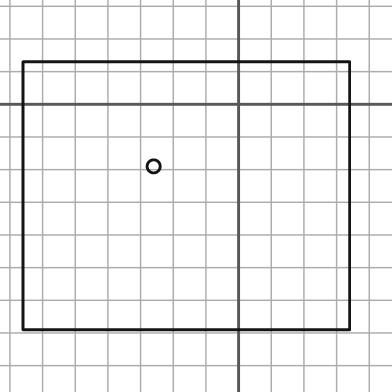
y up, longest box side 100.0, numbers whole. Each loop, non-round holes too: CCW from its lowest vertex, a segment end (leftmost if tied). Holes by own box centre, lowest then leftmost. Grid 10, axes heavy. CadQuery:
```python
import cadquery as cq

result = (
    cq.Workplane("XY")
    .moveTo(-66.0, -69.0)
    .lineTo(34.0, -69.0)
    .lineTo(34.0, 13.0)
    .lineTo(-66.0, 13.0)
    .close()
    .moveTo(-26.0, -19.0)
    .circle(2.0)
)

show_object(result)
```